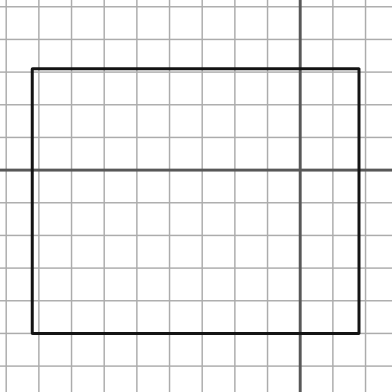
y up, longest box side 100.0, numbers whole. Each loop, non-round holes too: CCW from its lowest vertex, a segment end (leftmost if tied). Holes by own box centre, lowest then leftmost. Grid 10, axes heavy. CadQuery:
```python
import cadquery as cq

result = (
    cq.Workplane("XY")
    .moveTo(-82.0, -50.0)
    .lineTo(18.0, -50.0)
    .lineTo(18.0, 31.0)
    .lineTo(-82.0, 31.0)
    .close()
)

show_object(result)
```